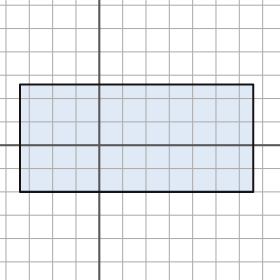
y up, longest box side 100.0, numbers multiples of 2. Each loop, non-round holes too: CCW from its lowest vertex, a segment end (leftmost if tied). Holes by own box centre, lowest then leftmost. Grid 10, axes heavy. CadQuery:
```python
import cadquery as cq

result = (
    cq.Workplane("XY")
    .moveTo(-34.0, -20.0)
    .lineTo(66.0, -20.0)
    .lineTo(66.0, 26.0)
    .lineTo(-34.0, 26.0)
    .close()
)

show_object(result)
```